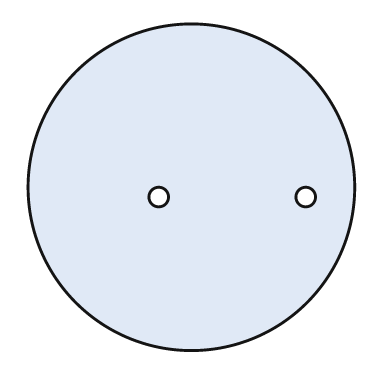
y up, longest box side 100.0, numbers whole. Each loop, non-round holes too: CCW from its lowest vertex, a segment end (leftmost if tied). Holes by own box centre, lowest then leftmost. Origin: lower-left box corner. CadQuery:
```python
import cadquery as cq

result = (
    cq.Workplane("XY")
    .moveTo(50.0, 50.0)
    .circle(50.0)
    .moveTo(40.0, 47.0)
    .circle(3.0)
    .moveTo(85.0, 47.0)
    .circle(3.0)
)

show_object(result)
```